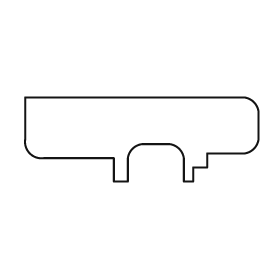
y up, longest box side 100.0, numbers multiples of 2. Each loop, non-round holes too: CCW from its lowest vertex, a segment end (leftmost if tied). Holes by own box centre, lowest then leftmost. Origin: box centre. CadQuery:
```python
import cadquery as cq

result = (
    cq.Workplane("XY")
    .moveTo(-12.0, -18.0)
    .lineTo(-6.0, -18.0)
    .lineTo(-6.0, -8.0)
    .threePointArc((-4.0, -4.0), (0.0, -2.0))
    .lineTo(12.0, -2.0)
    .threePointArc((16.0, -4.0), (18.0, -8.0))
    .lineTo(18.0, -18.0)
    .lineTo(22.0, -18.0)
    .lineTo(22.0, -12.0)
    .lineTo(28.0, -12.0)
    .lineTo(28.0, -6.0)
    .lineTo(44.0, -6.0)
    .threePointArc((48.0, -4.0), (50.0, 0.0))
    .lineTo(50.0, 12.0)
    .threePointArc((48.0, 16.0), (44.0, 18.0))
    .lineTo(-50.0, 18.0)
    .lineTo(-50.0, 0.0)
    .threePointArc((-48.0, -6.0), (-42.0, -8.0))
    .lineTo(-12.0, -8.0)
    .close()
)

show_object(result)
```